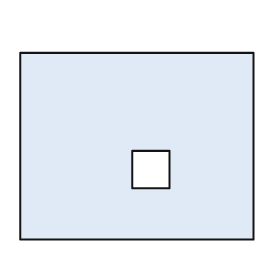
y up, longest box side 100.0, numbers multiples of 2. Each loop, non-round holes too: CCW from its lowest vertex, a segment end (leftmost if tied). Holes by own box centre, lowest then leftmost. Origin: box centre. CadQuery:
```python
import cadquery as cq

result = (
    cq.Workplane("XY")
    .moveTo(-50.0, -40.0)
    .lineTo(50.0, -40.0)
    .lineTo(50.0, 40.0)
    .lineTo(-50.0, 40.0)
    .close()
    .moveTo(-2.0, -18.0)
    .lineTo(14.0, -18.0)
    .lineTo(14.0, -2.0)
    .lineTo(-2.0, -2.0)
    .close()
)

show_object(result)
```